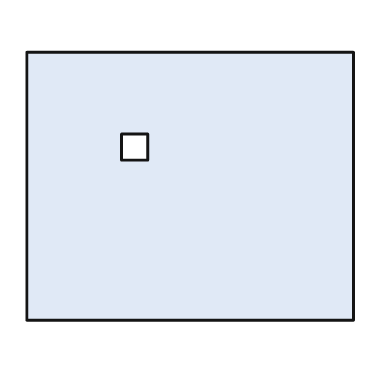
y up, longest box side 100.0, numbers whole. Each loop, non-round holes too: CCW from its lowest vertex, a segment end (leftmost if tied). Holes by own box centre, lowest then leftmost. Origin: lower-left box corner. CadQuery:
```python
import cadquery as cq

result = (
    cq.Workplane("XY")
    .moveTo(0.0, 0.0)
    .lineTo(100.0, 0.0)
    .lineTo(100.0, 82.0)
    .lineTo(0.0, 82.0)
    .close()
    .moveTo(29.0, 49.0)
    .lineTo(37.0, 49.0)
    .lineTo(37.0, 57.0)
    .lineTo(29.0, 57.0)
    .close()
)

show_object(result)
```